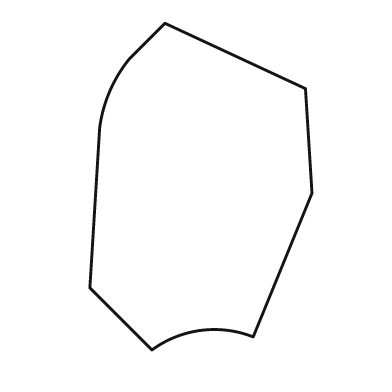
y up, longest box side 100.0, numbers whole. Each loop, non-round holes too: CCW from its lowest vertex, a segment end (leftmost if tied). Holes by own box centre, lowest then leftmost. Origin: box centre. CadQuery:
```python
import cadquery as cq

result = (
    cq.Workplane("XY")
    .moveTo(-15.0, -50.0)
    .threePointArc((0.0, -44.0), (16.0, -46.0))
    .lineTo(34.0, -2.0)
    .lineTo(32.0, 30.0)
    .lineTo(-11.0, 50.0)
    .lineTo(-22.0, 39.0)
    .threePointArc((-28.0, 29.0), (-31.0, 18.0))
    .lineTo(-34.0, -31.0)
    .close()
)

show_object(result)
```